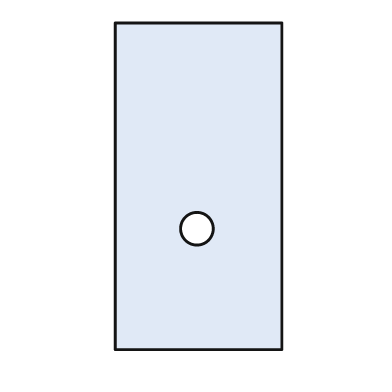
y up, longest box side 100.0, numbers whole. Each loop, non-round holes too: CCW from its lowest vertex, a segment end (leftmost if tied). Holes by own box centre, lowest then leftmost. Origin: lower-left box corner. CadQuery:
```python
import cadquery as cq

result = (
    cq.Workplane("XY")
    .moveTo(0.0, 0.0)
    .lineTo(51.0, 0.0)
    .lineTo(51.0, 100.0)
    .lineTo(0.0, 100.0)
    .close()
    .moveTo(25.0, 37.0)
    .circle(5.0)
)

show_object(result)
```